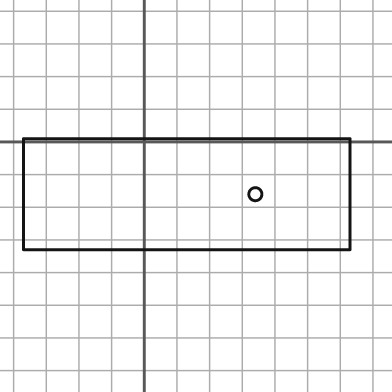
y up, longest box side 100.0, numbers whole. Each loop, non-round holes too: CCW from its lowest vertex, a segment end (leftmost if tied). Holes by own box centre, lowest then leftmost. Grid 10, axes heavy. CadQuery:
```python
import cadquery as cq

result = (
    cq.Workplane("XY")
    .moveTo(-37.0, -33.0)
    .lineTo(63.0, -33.0)
    .lineTo(63.0, 1.0)
    .lineTo(-37.0, 1.0)
    .close()
    .moveTo(34.0, -16.0)
    .circle(2.0)
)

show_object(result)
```